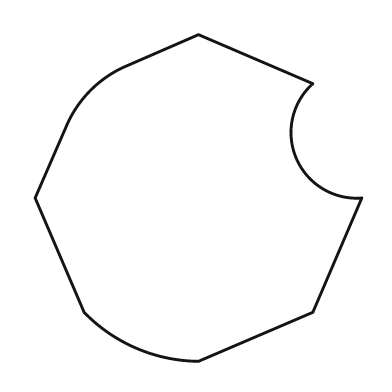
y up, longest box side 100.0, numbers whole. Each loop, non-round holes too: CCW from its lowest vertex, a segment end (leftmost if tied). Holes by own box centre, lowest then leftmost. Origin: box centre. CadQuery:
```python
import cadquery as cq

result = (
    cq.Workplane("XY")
    .moveTo(0.0, -50.0)
    .lineTo(35.0, -35.0)
    .lineTo(50.0, 0.0)
    .threePointArc((30.0, 12.0), (35.0, 35.0))
    .lineTo(0.0, 50.0)
    .lineTo(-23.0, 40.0)
    .threePointArc((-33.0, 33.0), (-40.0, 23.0))
    .lineTo(-50.0, 0.0)
    .lineTo(-35.0, -35.0)
    .threePointArc((-19.0, -46.0), (0.0, -50.0))
    .close()
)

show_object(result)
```